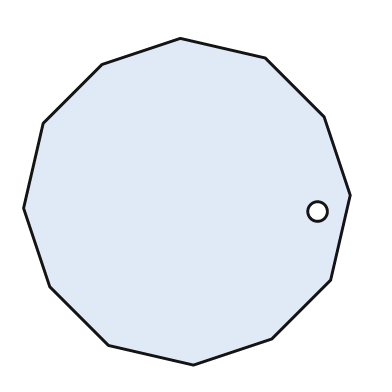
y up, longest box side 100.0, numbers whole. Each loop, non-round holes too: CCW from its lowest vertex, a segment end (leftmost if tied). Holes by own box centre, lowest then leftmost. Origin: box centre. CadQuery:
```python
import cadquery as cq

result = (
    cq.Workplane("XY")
    .moveTo(2.0, -50.0)
    .lineTo(26.0, -42.0)
    .lineTo(44.0, -24.0)
    .lineTo(50.0, 2.0)
    .lineTo(42.0, 26.0)
    .lineTo(24.0, 44.0)
    .lineTo(-2.0, 50.0)
    .lineTo(-26.0, 42.0)
    .lineTo(-44.0, 24.0)
    .lineTo(-50.0, -2.0)
    .lineTo(-42.0, -26.0)
    .lineTo(-24.0, -44.0)
    .close()
    .moveTo(40.0, -3.0)
    .circle(3.0)
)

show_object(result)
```